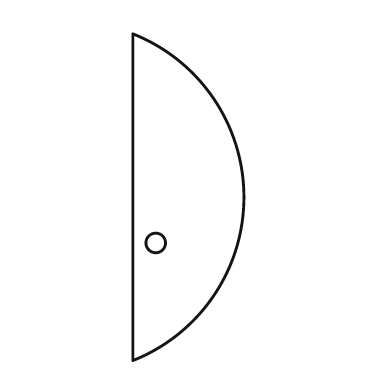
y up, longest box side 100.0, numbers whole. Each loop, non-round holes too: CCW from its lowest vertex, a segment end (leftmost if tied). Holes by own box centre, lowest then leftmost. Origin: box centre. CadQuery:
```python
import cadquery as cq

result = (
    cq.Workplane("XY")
    .moveTo(-17.0, -50.0)
    .threePointArc((17.0, 0.0), (-17.0, 50.0))
    .close()
    .moveTo(-10.0, -14.0)
    .circle(3.0)
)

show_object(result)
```